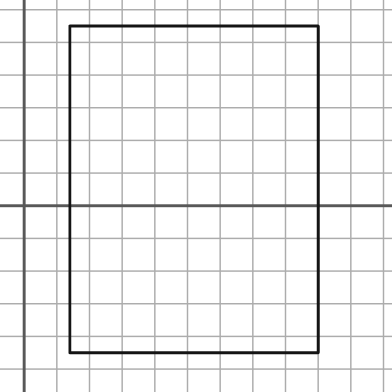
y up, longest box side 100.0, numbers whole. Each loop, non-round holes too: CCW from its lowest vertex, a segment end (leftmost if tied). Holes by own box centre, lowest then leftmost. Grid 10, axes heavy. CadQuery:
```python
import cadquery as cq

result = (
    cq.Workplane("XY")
    .moveTo(14.0, -45.0)
    .lineTo(90.0, -45.0)
    .lineTo(90.0, 55.0)
    .lineTo(14.0, 55.0)
    .close()
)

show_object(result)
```